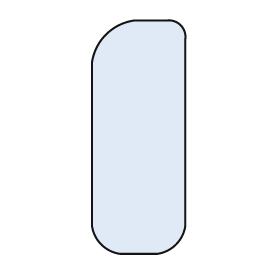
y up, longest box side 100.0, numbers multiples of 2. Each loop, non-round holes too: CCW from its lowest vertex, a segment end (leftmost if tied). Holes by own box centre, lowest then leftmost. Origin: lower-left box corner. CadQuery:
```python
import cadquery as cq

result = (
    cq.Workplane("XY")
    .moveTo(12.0, 0.0)
    .lineTo(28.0, 0.0)
    .threePointArc((36.0, 4.0), (40.0, 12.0))
    .lineTo(40.0, 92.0)
    .threePointArc((38.0, 98.0), (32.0, 100.0))
    .lineTo(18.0, 100.0)
    .threePointArc((6.0, 94.0), (0.0, 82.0))
    .lineTo(0.0, 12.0)
    .threePointArc((4.0, 4.0), (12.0, 0.0))
    .close()
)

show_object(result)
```